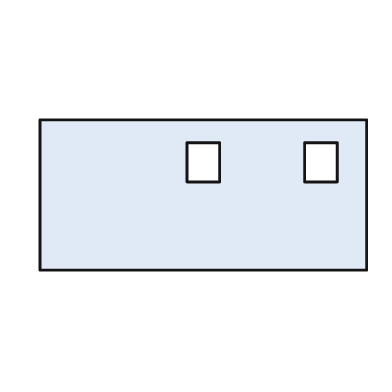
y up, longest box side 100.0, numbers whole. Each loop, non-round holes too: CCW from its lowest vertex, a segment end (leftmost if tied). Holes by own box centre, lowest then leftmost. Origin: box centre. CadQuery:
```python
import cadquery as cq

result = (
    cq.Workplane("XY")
    .moveTo(-50.0, -23.0)
    .lineTo(50.0, -23.0)
    .lineTo(50.0, 23.0)
    .lineTo(-50.0, 23.0)
    .close()
    .moveTo(-5.0, 4.0)
    .lineTo(5.0, 4.0)
    .lineTo(5.0, 16.0)
    .lineTo(-5.0, 16.0)
    .close()
    .moveTo(31.0, 4.0)
    .lineTo(41.0, 4.0)
    .lineTo(41.0, 16.0)
    .lineTo(31.0, 16.0)
    .close()
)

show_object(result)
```